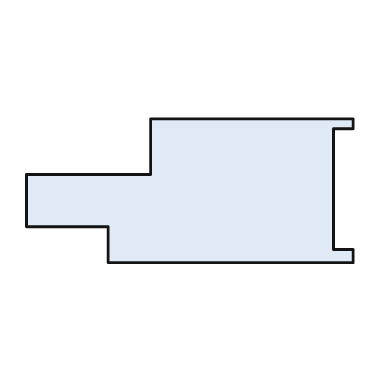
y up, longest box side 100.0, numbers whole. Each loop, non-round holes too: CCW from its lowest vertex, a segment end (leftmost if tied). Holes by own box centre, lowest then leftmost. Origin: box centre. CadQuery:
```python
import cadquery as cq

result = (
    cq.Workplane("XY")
    .moveTo(-25.0, -22.0)
    .lineTo(50.0, -22.0)
    .lineTo(50.0, -18.0)
    .lineTo(44.0, -18.0)
    .lineTo(44.0, 19.0)
    .lineTo(50.0, 19.0)
    .lineTo(50.0, 22.0)
    .lineTo(-12.0, 22.0)
    .lineTo(-12.0, 5.0)
    .lineTo(-50.0, 5.0)
    .lineTo(-50.0, -11.0)
    .lineTo(-25.0, -11.0)
    .close()
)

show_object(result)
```